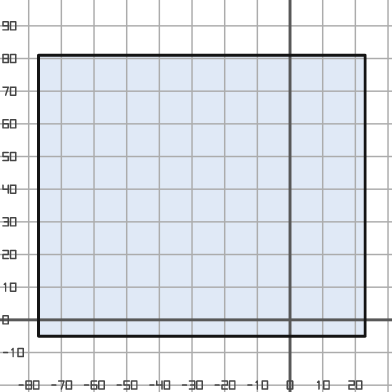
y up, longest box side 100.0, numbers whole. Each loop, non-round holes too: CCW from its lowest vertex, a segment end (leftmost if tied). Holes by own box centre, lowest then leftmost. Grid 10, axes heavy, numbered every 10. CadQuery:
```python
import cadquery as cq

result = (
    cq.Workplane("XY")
    .moveTo(-77.0, -5.0)
    .lineTo(23.0, -5.0)
    .lineTo(23.0, 81.0)
    .lineTo(-77.0, 81.0)
    .close()
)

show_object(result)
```